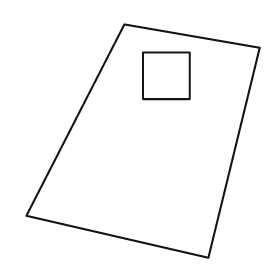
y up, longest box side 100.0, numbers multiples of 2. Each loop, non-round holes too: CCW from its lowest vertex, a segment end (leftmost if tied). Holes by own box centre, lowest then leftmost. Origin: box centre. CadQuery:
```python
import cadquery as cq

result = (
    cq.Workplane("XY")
    .moveTo(28.0, -50.0)
    .lineTo(50.0, 40.0)
    .lineTo(-8.0, 50.0)
    .lineTo(-50.0, -32.0)
    .close()
    .moveTo(0.0, 18.0)
    .lineTo(20.0, 18.0)
    .lineTo(20.0, 38.0)
    .lineTo(0.0, 38.0)
    .close()
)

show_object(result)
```